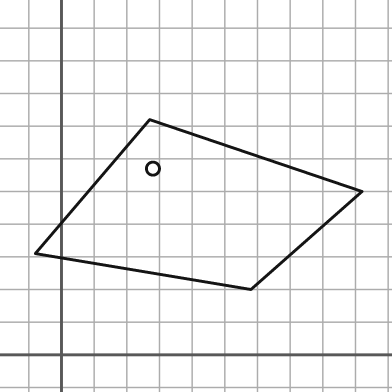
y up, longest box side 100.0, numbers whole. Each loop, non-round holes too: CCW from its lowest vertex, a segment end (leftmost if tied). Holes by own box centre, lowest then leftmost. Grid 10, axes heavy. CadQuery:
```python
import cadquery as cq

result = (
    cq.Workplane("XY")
    .moveTo(58.0, 20.0)
    .lineTo(92.0, 50.0)
    .lineTo(27.0, 72.0)
    .lineTo(-8.0, 31.0)
    .close()
    .moveTo(28.0, 57.0)
    .circle(2.0)
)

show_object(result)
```